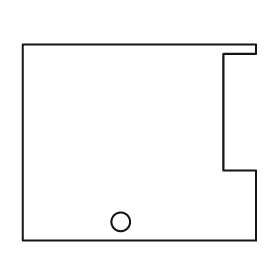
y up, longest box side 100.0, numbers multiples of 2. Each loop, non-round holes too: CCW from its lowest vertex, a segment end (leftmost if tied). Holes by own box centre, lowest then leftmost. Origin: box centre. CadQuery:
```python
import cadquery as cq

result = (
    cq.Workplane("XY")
    .moveTo(-50.0, -42.0)
    .lineTo(50.0, -42.0)
    .lineTo(50.0, -12.0)
    .lineTo(36.0, -12.0)
    .lineTo(36.0, 38.0)
    .lineTo(50.0, 38.0)
    .lineTo(50.0, 42.0)
    .lineTo(-50.0, 42.0)
    .close()
    .moveTo(-8.0, -34.0)
    .circle(4.0)
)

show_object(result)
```